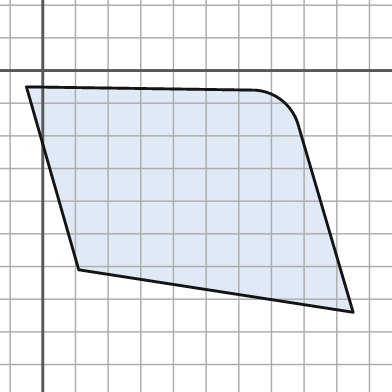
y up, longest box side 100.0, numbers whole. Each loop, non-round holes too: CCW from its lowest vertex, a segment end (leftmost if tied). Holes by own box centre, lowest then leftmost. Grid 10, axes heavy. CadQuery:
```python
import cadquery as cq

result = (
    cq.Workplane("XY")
    .moveTo(95.0, -74.0)
    .lineTo(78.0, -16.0)
    .threePointArc((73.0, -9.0), (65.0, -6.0))
    .lineTo(-5.0, -5.0)
    .lineTo(11.0, -61.0)
    .close()
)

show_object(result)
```